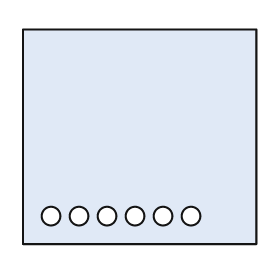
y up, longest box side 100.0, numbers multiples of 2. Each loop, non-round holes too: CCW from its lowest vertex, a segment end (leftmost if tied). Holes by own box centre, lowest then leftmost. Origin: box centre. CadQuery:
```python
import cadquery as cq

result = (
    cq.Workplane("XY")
    .moveTo(-50.0, -46.0)
    .lineTo(50.0, -46.0)
    .lineTo(50.0, 46.0)
    .lineTo(-50.0, 46.0)
    .close()
    .moveTo(-38.0, -34.0)
    .circle(4.0)
    .moveTo(-26.0, -34.0)
    .circle(4.0)
    .moveTo(-14.0, -34.0)
    .circle(4.0)
    .moveTo(-2.0, -34.0)
    .circle(4.0)
    .moveTo(10.0, -34.0)
    .circle(4.0)
    .moveTo(22.0, -34.0)
    .circle(4.0)
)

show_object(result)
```